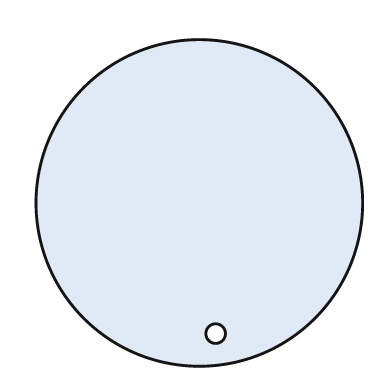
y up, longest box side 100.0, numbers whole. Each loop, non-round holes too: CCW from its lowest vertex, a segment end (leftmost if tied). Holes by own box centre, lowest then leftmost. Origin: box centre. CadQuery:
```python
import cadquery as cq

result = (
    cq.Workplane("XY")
    .moveTo(0.0, 0.0)
    .circle(50.0)
    .moveTo(5.0, -40.0)
    .circle(3.0)
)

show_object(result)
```